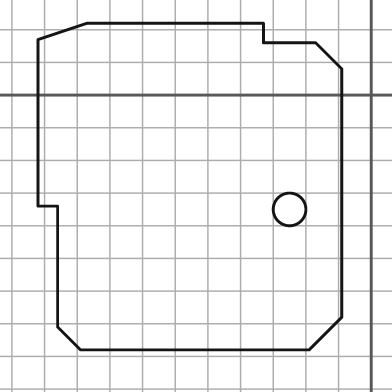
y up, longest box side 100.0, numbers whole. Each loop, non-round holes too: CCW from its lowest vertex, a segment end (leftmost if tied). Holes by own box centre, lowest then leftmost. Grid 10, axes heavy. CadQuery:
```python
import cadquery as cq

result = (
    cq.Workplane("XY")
    .moveTo(-89.0, -78.0)
    .lineTo(-19.0, -78.0)
    .lineTo(-9.0, -68.0)
    .lineTo(-9.0, 8.0)
    .lineTo(-17.0, 16.0)
    .lineTo(-33.0, 16.0)
    .lineTo(-33.0, 22.0)
    .lineTo(-87.0, 22.0)
    .lineTo(-102.0, 17.0)
    .lineTo(-102.0, -34.0)
    .lineTo(-96.0, -34.0)
    .lineTo(-96.0, -71.0)
    .close()
    .moveTo(-25.0, -35.0)
    .circle(5.0)
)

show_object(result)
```